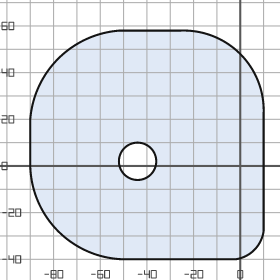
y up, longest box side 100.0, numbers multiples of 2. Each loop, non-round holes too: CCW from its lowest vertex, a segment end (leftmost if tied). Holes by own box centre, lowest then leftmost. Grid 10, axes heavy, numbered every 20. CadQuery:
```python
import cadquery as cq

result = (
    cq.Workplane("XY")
    .moveTo(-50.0, -40.0)
    .lineTo(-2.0, -40.0)
    .threePointArc((6.0, -36.0), (10.0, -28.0))
    .lineTo(10.0, 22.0)
    .threePointArc((0.0, 48.0), (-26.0, 58.0))
    .lineTo(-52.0, 58.0)
    .threePointArc((-78.0, 46.0), (-90.0, 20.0))
    .lineTo(-90.0, 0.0)
    .threePointArc((-78.0, -28.0), (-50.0, -40.0))
    .close()
    .moveTo(-44.0, 2.0)
    .circle(8.0)
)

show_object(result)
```